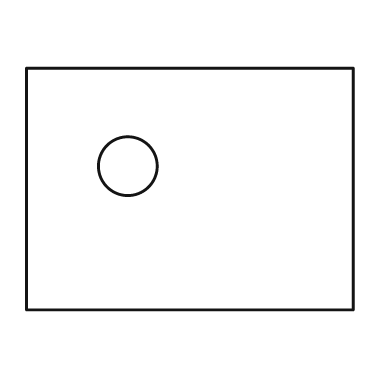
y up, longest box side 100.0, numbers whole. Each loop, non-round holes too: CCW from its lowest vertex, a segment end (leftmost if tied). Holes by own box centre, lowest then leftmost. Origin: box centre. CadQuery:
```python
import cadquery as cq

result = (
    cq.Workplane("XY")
    .moveTo(-50.0, -37.0)
    .lineTo(50.0, -37.0)
    .lineTo(50.0, 37.0)
    .lineTo(-50.0, 37.0)
    .close()
    .moveTo(-19.0, 7.0)
    .circle(9.0)
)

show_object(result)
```